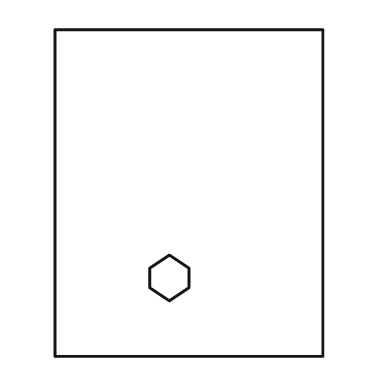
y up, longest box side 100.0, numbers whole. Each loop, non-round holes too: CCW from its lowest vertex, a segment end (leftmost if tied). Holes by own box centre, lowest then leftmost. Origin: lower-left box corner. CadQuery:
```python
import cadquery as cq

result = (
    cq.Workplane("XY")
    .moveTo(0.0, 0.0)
    .lineTo(82.0, 0.0)
    .lineTo(82.0, 100.0)
    .lineTo(0.0, 100.0)
    .close()
    .moveTo(35.0, 17.0)
    .lineTo(41.0, 21.0)
    .lineTo(41.0, 27.0)
    .lineTo(35.0, 31.0)
    .lineTo(29.0, 27.0)
    .lineTo(29.0, 21.0)
    .close()
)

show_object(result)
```